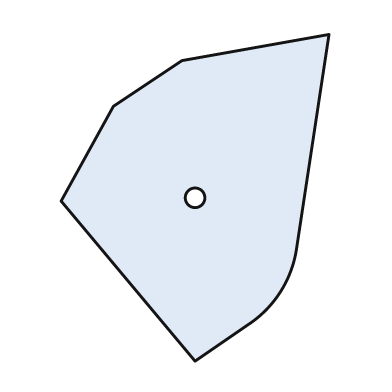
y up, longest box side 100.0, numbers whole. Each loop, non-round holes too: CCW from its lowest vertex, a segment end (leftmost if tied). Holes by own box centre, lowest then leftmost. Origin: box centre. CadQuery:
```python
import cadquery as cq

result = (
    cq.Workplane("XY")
    .moveTo(0.0, -50.0)
    .lineTo(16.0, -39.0)
    .threePointArc((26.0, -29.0), (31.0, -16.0))
    .lineTo(41.0, 50.0)
    .lineTo(-4.0, 42.0)
    .lineTo(-25.0, 28.0)
    .lineTo(-41.0, -1.0)
    .close()
    .moveTo(0.0, 0.0)
    .circle(3.0)
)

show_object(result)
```